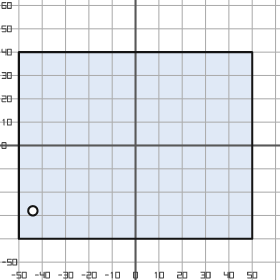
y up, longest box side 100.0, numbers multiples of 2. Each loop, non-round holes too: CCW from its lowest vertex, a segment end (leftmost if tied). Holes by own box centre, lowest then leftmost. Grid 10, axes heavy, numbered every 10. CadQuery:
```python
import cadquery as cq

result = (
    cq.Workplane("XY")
    .moveTo(-50.0, -40.0)
    .lineTo(50.0, -40.0)
    .lineTo(50.0, 40.0)
    .lineTo(-50.0, 40.0)
    .close()
    .moveTo(-44.0, -28.0)
    .circle(2.0)
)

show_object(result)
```